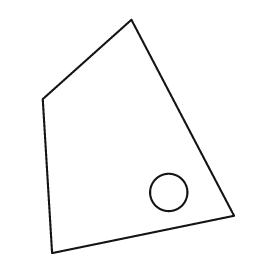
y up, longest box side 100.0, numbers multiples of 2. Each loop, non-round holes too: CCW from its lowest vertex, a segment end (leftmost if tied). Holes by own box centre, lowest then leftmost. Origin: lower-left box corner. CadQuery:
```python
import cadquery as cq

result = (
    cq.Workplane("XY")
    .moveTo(4.0, 0.0)
    .lineTo(82.0, 16.0)
    .lineTo(38.0, 100.0)
    .lineTo(0.0, 66.0)
    .close()
    .moveTo(54.0, 26.0)
    .circle(8.0)
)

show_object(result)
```